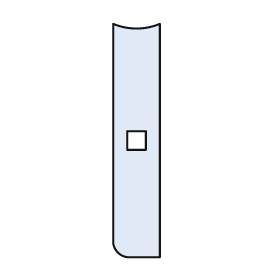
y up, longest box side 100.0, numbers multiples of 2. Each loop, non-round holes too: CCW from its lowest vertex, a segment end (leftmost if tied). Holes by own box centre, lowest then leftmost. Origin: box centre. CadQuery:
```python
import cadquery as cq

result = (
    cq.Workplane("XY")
    .moveTo(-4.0, -50.0)
    .lineTo(10.0, -50.0)
    .lineTo(10.0, 50.0)
    .threePointArc((0.0, 48.0), (-10.0, 50.0))
    .lineTo(-10.0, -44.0)
    .threePointArc((-8.0, -48.0), (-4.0, -50.0))
    .close()
    .moveTo(-4.0, -4.0)
    .lineTo(4.0, -4.0)
    .lineTo(4.0, 4.0)
    .lineTo(-4.0, 4.0)
    .close()
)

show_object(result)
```